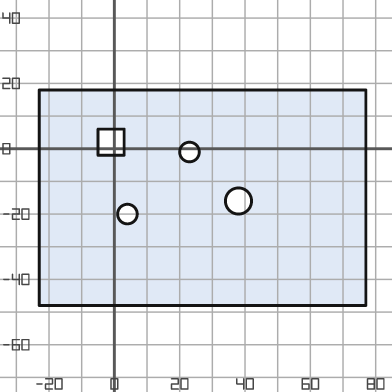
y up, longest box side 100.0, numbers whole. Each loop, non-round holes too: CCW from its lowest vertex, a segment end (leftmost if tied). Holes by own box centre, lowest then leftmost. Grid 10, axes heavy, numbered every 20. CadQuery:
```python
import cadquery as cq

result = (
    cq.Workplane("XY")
    .moveTo(-23.0, -48.0)
    .lineTo(77.0, -48.0)
    .lineTo(77.0, 18.0)
    .lineTo(-23.0, 18.0)
    .close()
    .moveTo(4.0, -20.0)
    .circle(3.0)
    .moveTo(38.0, -16.0)
    .circle(4.0)
    .moveTo(23.0, -1.0)
    .circle(3.0)
    .moveTo(-5.0, -2.0)
    .lineTo(3.0, -2.0)
    .lineTo(3.0, 6.0)
    .lineTo(-5.0, 6.0)
    .close()
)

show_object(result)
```